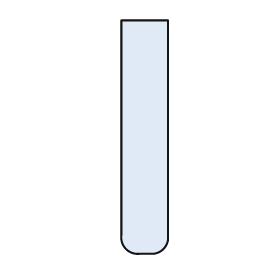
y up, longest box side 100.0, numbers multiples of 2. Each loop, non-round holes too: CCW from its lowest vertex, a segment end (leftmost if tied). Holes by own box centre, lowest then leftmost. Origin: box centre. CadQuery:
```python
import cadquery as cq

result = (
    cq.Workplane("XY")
    .moveTo(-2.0, -50.0)
    .lineTo(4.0, -50.0)
    .threePointArc((8.0, -48.0), (10.0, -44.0))
    .lineTo(10.0, 50.0)
    .lineTo(-10.0, 50.0)
    .lineTo(-10.0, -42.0)
    .threePointArc((-8.0, -48.0), (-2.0, -50.0))
    .close()
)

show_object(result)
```